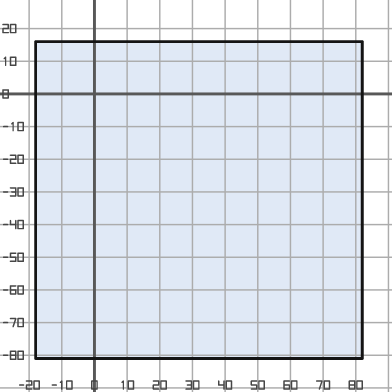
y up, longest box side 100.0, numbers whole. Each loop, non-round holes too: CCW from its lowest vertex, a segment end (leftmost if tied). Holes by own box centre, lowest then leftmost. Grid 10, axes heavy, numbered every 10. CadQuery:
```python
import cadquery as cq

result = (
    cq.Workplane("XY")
    .moveTo(-18.0, -81.0)
    .lineTo(82.0, -81.0)
    .lineTo(82.0, 16.0)
    .lineTo(-18.0, 16.0)
    .close()
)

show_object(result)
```